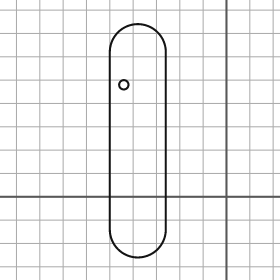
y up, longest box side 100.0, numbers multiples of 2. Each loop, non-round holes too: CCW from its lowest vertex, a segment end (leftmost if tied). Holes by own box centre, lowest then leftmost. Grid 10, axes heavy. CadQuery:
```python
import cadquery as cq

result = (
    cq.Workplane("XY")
    .moveTo(-50.0, -14.0)
    .threePointArc((-38.0, -26.0), (-26.0, -14.0))
    .lineTo(-26.0, 62.0)
    .threePointArc((-38.0, 74.0), (-50.0, 62.0))
    .close()
    .moveTo(-44.0, 48.0)
    .circle(2.0)
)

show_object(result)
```